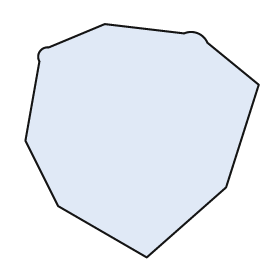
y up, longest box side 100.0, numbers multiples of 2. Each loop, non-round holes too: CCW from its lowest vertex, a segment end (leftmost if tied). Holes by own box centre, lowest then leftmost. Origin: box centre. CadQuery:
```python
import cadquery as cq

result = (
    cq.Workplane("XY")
    .moveTo(2.0, -50.0)
    .lineTo(36.0, -20.0)
    .lineTo(50.0, 24.0)
    .lineTo(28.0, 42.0)
    .threePointArc((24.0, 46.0), (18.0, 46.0))
    .lineTo(-16.0, 50.0)
    .lineTo(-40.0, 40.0)
    .threePointArc((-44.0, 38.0), (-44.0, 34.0))
    .lineTo(-50.0, 0.0)
    .lineTo(-36.0, -28.0)
    .close()
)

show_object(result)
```